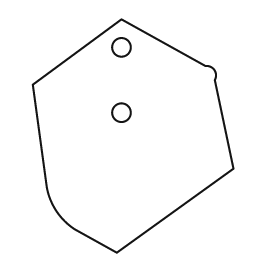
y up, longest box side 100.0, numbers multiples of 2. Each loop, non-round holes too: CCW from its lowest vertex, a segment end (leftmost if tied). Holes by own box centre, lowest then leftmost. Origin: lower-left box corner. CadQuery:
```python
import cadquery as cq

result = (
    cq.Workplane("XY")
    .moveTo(36.0, 0.0)
    .lineTo(86.0, 36.0)
    .lineTo(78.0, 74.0)
    .threePointArc((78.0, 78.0), (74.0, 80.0))
    .lineTo(38.0, 100.0)
    .lineTo(0.0, 72.0)
    .lineTo(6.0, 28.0)
    .threePointArc((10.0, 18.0), (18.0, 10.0))
    .close()
    .moveTo(38.0, 60.0)
    .circle(4.0)
    .moveTo(38.0, 88.0)
    .circle(4.0)
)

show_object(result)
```